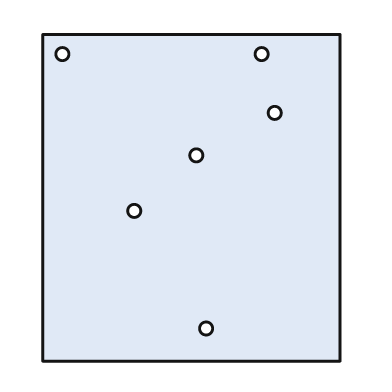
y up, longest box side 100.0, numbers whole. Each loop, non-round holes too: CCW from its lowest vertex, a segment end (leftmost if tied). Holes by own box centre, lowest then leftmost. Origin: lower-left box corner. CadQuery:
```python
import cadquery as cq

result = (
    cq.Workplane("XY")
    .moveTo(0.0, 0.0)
    .lineTo(91.0, 0.0)
    .lineTo(91.0, 100.0)
    .lineTo(0.0, 100.0)
    .close()
    .moveTo(50.0, 10.0)
    .circle(2.0)
    .moveTo(28.0, 46.0)
    .circle(2.0)
    .moveTo(47.0, 63.0)
    .circle(2.0)
    .moveTo(71.0, 76.0)
    .circle(2.0)
    .moveTo(6.0, 94.0)
    .circle(2.0)
    .moveTo(67.0, 94.0)
    .circle(2.0)
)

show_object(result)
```